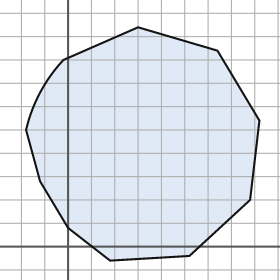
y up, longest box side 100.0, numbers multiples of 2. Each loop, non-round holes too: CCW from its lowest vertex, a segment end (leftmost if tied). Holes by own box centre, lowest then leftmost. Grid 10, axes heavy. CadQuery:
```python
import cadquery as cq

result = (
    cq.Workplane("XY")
    .moveTo(18.0, -6.0)
    .lineTo(52.0, -4.0)
    .lineTo(78.0, 20.0)
    .lineTo(82.0, 54.0)
    .lineTo(64.0, 84.0)
    .lineTo(30.0, 94.0)
    .lineTo(-2.0, 80.0)
    .threePointArc((-12.0, 66.0), (-18.0, 50.0))
    .lineTo(-12.0, 28.0)
    .lineTo(0.0, 8.0)
    .close()
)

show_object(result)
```